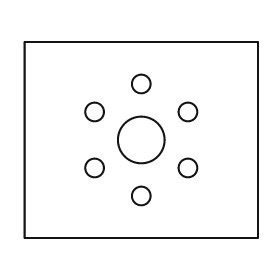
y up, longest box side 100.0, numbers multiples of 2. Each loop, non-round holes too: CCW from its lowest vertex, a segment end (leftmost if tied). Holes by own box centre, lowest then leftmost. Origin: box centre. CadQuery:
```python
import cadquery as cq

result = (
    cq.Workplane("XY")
    .moveTo(-50.0, -42.0)
    .lineTo(50.0, -42.0)
    .lineTo(50.0, 42.0)
    .lineTo(-50.0, 42.0)
    .close()
    .moveTo(0.0, -24.0)
    .circle(4.0)
    .moveTo(-20.0, -12.0)
    .circle(4.0)
    .moveTo(20.0, -12.0)
    .circle(4.0)
    .moveTo(0.0, 0.0)
    .circle(10.0)
    .moveTo(-20.0, 12.0)
    .circle(4.0)
    .moveTo(20.0, 12.0)
    .circle(4.0)
    .moveTo(0.0, 24.0)
    .circle(4.0)
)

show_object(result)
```